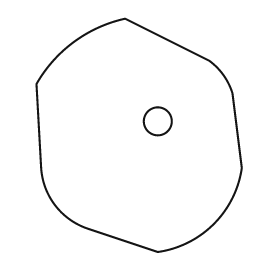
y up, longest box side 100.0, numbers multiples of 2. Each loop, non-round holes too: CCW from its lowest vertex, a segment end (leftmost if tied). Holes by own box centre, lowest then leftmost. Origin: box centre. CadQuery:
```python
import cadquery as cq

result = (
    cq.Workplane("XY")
    .moveTo(8.0, -50.0)
    .threePointArc((32.0, -38.0), (44.0, -14.0))
    .lineTo(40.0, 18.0)
    .threePointArc((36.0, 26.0), (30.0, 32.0))
    .lineTo(-6.0, 50.0)
    .threePointArc((-28.0, 40.0), (-44.0, 22.0))
    .lineTo(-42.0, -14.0)
    .threePointArc((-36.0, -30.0), (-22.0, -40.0))
    .close()
    .moveTo(8.0, 6.0)
    .circle(6.0)
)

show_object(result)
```